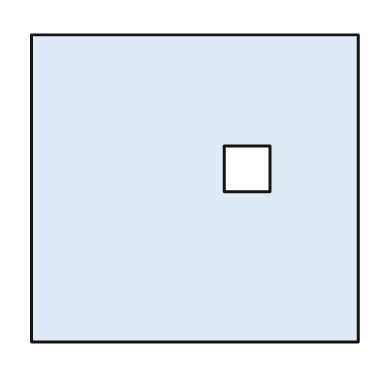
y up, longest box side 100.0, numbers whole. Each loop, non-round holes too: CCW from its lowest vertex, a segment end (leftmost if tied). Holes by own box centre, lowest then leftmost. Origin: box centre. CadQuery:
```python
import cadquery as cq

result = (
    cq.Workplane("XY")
    .moveTo(-50.0, -47.0)
    .lineTo(50.0, -47.0)
    .lineTo(50.0, 47.0)
    .lineTo(-50.0, 47.0)
    .close()
    .moveTo(9.0, -1.0)
    .lineTo(23.0, -1.0)
    .lineTo(23.0, 13.0)
    .lineTo(9.0, 13.0)
    .close()
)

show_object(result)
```